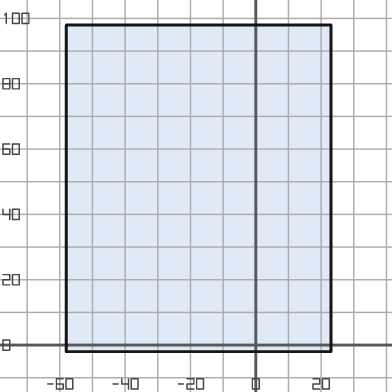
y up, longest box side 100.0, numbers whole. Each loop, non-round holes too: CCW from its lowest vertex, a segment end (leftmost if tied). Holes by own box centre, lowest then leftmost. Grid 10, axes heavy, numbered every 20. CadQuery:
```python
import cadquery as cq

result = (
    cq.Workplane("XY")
    .moveTo(-58.0, -2.0)
    .lineTo(23.0, -2.0)
    .lineTo(23.0, 98.0)
    .lineTo(-58.0, 98.0)
    .close()
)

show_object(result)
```